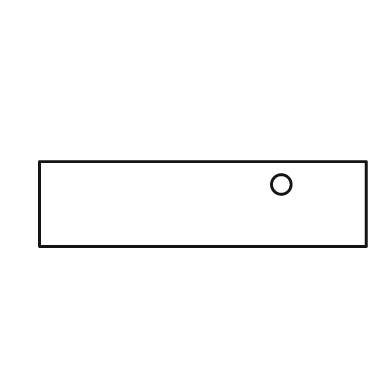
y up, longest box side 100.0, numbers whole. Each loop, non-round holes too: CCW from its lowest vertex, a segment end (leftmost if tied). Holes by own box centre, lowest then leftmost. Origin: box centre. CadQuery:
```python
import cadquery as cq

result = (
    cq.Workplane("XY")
    .moveTo(-50.0, -13.0)
    .lineTo(50.0, -13.0)
    .lineTo(50.0, 13.0)
    .lineTo(-50.0, 13.0)
    .close()
    .moveTo(24.0, 6.0)
    .circle(3.0)
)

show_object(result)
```